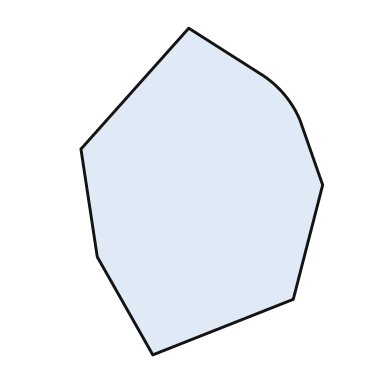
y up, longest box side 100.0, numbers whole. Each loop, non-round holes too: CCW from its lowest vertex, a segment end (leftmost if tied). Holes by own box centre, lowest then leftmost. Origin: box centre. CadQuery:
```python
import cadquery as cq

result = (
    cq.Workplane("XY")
    .moveTo(-15.0, -50.0)
    .lineTo(28.0, -33.0)
    .lineTo(37.0, 2.0)
    .lineTo(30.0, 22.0)
    .threePointArc((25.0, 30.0), (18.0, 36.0))
    .lineTo(-4.0, 50.0)
    .lineTo(-37.0, 13.0)
    .lineTo(-32.0, -20.0)
    .close()
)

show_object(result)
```